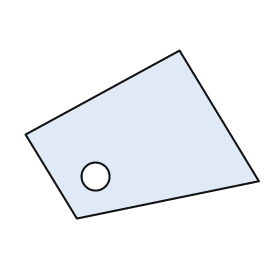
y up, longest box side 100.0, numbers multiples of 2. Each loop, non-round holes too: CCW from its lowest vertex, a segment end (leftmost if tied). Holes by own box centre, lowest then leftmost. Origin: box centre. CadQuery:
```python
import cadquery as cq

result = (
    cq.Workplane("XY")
    .moveTo(-28.0, -36.0)
    .lineTo(50.0, -20.0)
    .lineTo(16.0, 36.0)
    .lineTo(-50.0, 0.0)
    .close()
    .moveTo(-20.0, -18.0)
    .circle(6.0)
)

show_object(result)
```